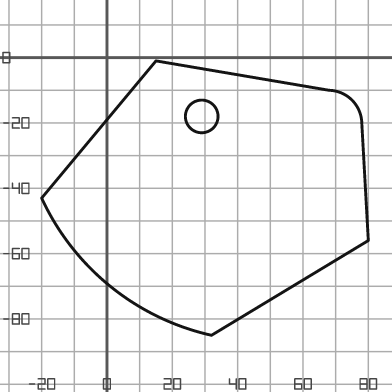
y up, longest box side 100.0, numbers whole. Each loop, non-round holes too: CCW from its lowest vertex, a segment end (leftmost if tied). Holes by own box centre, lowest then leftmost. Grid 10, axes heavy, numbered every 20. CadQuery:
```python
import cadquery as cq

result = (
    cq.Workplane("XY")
    .moveTo(32.0, -85.0)
    .lineTo(80.0, -56.0)
    .lineTo(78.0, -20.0)
    .threePointArc((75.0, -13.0), (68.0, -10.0))
    .lineTo(15.0, -1.0)
    .lineTo(-20.0, -43.0)
    .threePointArc((1.0, -70.0), (32.0, -85.0))
    .close()
    .moveTo(29.0, -18.0)
    .circle(5.0)
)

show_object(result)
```